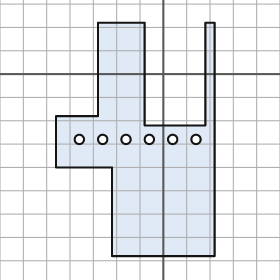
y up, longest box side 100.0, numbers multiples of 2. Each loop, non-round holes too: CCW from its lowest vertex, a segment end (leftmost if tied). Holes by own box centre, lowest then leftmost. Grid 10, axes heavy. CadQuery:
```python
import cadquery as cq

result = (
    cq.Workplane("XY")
    .moveTo(-22.0, -78.0)
    .lineTo(22.0, -78.0)
    .lineTo(22.0, 22.0)
    .lineTo(18.0, 22.0)
    .lineTo(18.0, -22.0)
    .lineTo(-8.0, -22.0)
    .lineTo(-8.0, 22.0)
    .lineTo(-28.0, 22.0)
    .lineTo(-28.0, -18.0)
    .lineTo(-46.0, -18.0)
    .lineTo(-46.0, -40.0)
    .lineTo(-22.0, -40.0)
    .close()
    .moveTo(-36.0, -28.0)
    .circle(2.0)
    .moveTo(-26.0, -28.0)
    .circle(2.0)
    .moveTo(-16.0, -28.0)
    .circle(2.0)
    .moveTo(-6.0, -28.0)
    .circle(2.0)
    .moveTo(4.0, -28.0)
    .circle(2.0)
    .moveTo(14.0, -28.0)
    .circle(2.0)
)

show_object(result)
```